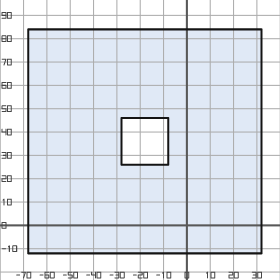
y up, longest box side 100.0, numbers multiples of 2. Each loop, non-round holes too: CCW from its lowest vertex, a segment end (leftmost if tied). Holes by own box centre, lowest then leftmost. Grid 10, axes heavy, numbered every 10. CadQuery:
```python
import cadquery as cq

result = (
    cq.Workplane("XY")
    .moveTo(-68.0, -12.0)
    .lineTo(32.0, -12.0)
    .lineTo(32.0, 84.0)
    .lineTo(-68.0, 84.0)
    .close()
    .moveTo(-28.0, 26.0)
    .lineTo(-8.0, 26.0)
    .lineTo(-8.0, 46.0)
    .lineTo(-28.0, 46.0)
    .close()
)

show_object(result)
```